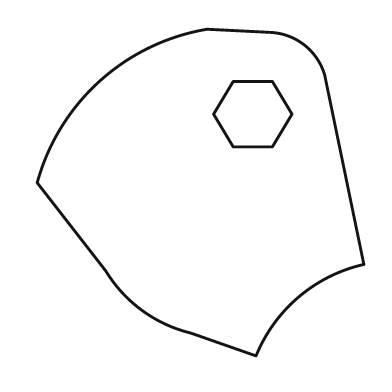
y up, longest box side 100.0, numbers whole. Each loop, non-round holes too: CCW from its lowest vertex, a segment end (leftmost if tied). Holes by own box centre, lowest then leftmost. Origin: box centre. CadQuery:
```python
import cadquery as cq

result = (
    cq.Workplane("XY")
    .moveTo(17.0, -50.0)
    .threePointArc((30.0, -32.0), (50.0, -22.0))
    .lineTo(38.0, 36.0)
    .threePointArc((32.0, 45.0), (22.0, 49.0))
    .lineTo(2.0, 50.0)
    .threePointArc((-31.0, 34.0), (-50.0, 3.0))
    .lineTo(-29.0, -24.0)
    .threePointArc((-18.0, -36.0), (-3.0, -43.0))
    .close()
    .moveTo(10.0, 14.0)
    .lineTo(22.0, 14.0)
    .lineTo(28.0, 24.0)
    .lineTo(22.0, 34.0)
    .lineTo(10.0, 34.0)
    .lineTo(4.0, 24.0)
    .close()
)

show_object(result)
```